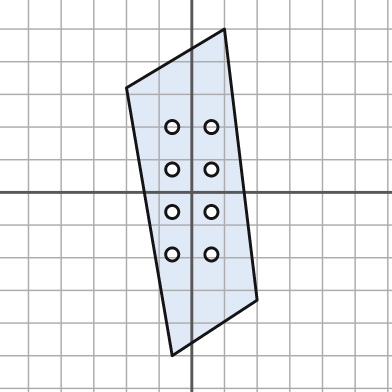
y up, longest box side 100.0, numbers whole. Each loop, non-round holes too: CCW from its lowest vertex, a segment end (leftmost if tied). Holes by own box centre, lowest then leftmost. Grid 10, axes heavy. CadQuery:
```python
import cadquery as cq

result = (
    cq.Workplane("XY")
    .moveTo(-6.0, -50.0)
    .lineTo(20.0, -33.0)
    .lineTo(10.0, 50.0)
    .lineTo(-20.0, 32.0)
    .close()
    .moveTo(-6.0, -19.0)
    .circle(2.0)
    .moveTo(6.0, -19.0)
    .circle(2.0)
    .moveTo(-6.0, -6.0)
    .circle(2.0)
    .moveTo(6.0, -6.0)
    .circle(2.0)
    .moveTo(-6.0, 7.0)
    .circle(2.0)
    .moveTo(6.0, 7.0)
    .circle(2.0)
    .moveTo(-6.0, 20.0)
    .circle(2.0)
    .moveTo(6.0, 20.0)
    .circle(2.0)
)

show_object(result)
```